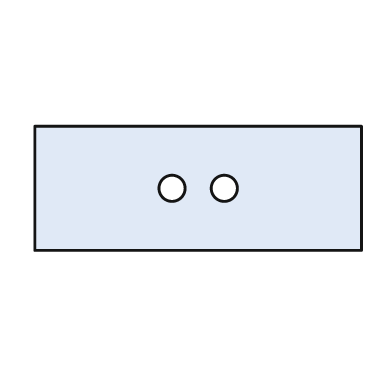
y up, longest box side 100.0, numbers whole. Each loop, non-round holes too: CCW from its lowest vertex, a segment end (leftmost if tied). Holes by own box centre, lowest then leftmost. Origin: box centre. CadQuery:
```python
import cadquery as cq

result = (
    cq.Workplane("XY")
    .moveTo(-50.0, -19.0)
    .lineTo(50.0, -19.0)
    .lineTo(50.0, 19.0)
    .lineTo(-50.0, 19.0)
    .close()
    .moveTo(-8.0, 0.0)
    .circle(4.0)
    .moveTo(8.0, 0.0)
    .circle(4.0)
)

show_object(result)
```